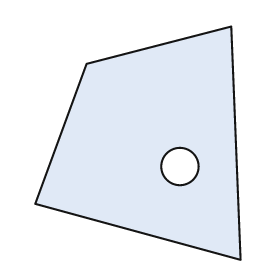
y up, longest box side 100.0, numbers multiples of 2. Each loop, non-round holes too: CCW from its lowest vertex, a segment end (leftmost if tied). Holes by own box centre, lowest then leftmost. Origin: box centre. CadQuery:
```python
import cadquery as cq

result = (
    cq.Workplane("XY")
    .moveTo(44.0, -50.0)
    .lineTo(40.0, 50.0)
    .lineTo(-22.0, 34.0)
    .lineTo(-44.0, -26.0)
    .close()
    .moveTo(18.0, -10.0)
    .circle(8.0)
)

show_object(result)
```